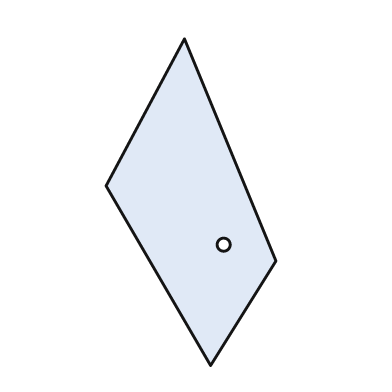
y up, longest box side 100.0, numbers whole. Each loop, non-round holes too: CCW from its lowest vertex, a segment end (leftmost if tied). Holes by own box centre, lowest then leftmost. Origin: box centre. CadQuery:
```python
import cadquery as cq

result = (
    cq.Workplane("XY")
    .moveTo(6.0, -50.0)
    .lineTo(26.0, -18.0)
    .lineTo(-2.0, 50.0)
    .lineTo(-26.0, 5.0)
    .close()
    .moveTo(10.0, -13.0)
    .circle(2.0)
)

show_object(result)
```